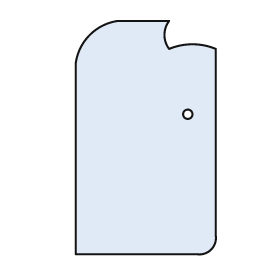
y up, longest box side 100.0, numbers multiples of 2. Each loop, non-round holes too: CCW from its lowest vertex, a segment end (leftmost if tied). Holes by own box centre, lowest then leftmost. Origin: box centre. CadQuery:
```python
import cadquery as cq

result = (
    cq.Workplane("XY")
    .moveTo(-30.0, -50.0)
    .lineTo(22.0, -50.0)
    .threePointArc((28.0, -48.0), (30.0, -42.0))
    .lineTo(30.0, 38.0)
    .threePointArc((20.0, 40.0), (10.0, 38.0))
    .threePointArc((8.0, 44.0), (10.0, 50.0))
    .lineTo(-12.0, 50.0)
    .threePointArc((-24.0, 44.0), (-30.0, 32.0))
    .close()
    .moveTo(18.0, 10.0)
    .circle(2.0)
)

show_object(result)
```